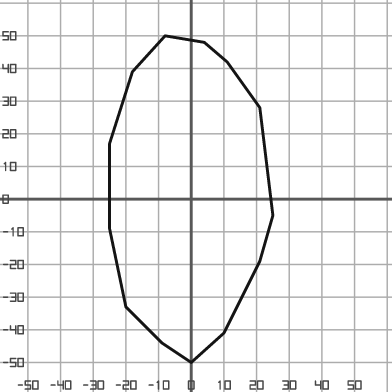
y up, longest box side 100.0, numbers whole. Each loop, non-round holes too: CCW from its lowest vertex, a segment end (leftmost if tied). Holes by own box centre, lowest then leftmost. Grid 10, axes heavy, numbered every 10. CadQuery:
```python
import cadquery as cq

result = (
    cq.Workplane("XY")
    .moveTo(0.0, -50.0)
    .lineTo(10.0, -41.0)
    .lineTo(21.0, -19.0)
    .lineTo(25.0, -5.0)
    .lineTo(21.0, 28.0)
    .lineTo(11.0, 42.0)
    .lineTo(4.0, 48.0)
    .lineTo(-8.0, 50.0)
    .lineTo(-18.0, 39.0)
    .lineTo(-25.0, 17.0)
    .lineTo(-25.0, -9.0)
    .lineTo(-20.0, -33.0)
    .lineTo(-9.0, -44.0)
    .close()
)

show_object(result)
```